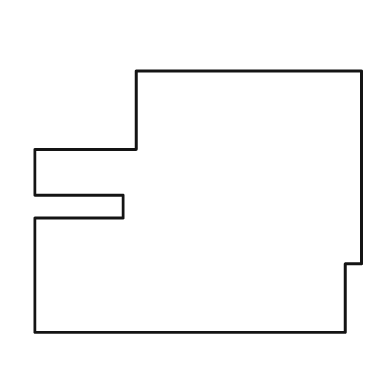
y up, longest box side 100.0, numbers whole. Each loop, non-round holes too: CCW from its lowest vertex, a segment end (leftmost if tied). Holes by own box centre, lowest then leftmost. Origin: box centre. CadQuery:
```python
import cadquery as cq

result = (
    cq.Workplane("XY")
    .moveTo(-50.0, -40.0)
    .lineTo(45.0, -40.0)
    .lineTo(45.0, -19.0)
    .lineTo(50.0, -19.0)
    .lineTo(50.0, 40.0)
    .lineTo(-19.0, 40.0)
    .lineTo(-19.0, 16.0)
    .lineTo(-50.0, 16.0)
    .lineTo(-50.0, 2.0)
    .lineTo(-23.0, 2.0)
    .lineTo(-23.0, -5.0)
    .lineTo(-50.0, -5.0)
    .close()
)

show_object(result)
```